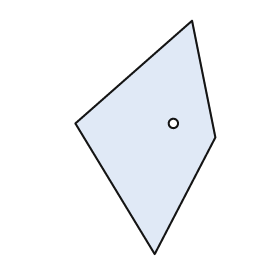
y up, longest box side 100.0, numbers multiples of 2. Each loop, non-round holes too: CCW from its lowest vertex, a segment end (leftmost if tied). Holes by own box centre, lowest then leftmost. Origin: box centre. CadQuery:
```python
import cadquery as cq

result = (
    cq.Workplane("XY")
    .moveTo(4.0, -50.0)
    .lineTo(30.0, 0.0)
    .lineTo(20.0, 50.0)
    .lineTo(-30.0, 6.0)
    .close()
    .moveTo(12.0, 6.0)
    .circle(2.0)
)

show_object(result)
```